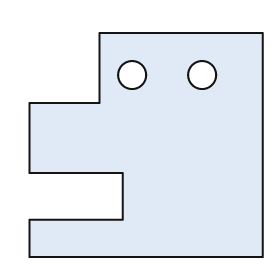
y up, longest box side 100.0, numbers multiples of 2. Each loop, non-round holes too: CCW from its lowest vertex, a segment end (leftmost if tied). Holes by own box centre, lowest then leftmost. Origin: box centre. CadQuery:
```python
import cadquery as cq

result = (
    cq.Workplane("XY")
    .moveTo(-50.0, -48.0)
    .lineTo(50.0, -48.0)
    .lineTo(50.0, 48.0)
    .lineTo(-20.0, 48.0)
    .lineTo(-20.0, 18.0)
    .lineTo(-50.0, 18.0)
    .lineTo(-50.0, -12.0)
    .lineTo(-10.0, -12.0)
    .lineTo(-10.0, -32.0)
    .lineTo(-50.0, -32.0)
    .close()
    .moveTo(-6.0, 30.0)
    .circle(6.0)
    .moveTo(24.0, 30.0)
    .circle(6.0)
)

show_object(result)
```